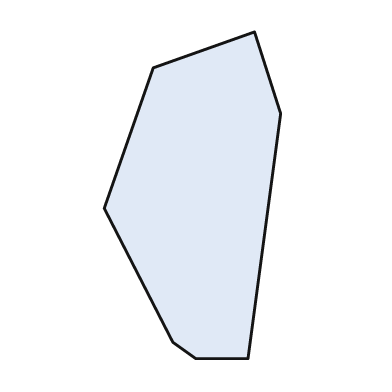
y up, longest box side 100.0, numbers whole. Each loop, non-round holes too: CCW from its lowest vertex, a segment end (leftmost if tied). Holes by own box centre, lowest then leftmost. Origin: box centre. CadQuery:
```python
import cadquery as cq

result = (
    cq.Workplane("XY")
    .moveTo(1.0, -50.0)
    .lineTo(17.0, -50.0)
    .lineTo(27.0, 25.0)
    .lineTo(19.0, 50.0)
    .lineTo(-12.0, 39.0)
    .lineTo(-27.0, -4.0)
    .lineTo(-6.0, -45.0)
    .close()
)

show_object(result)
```